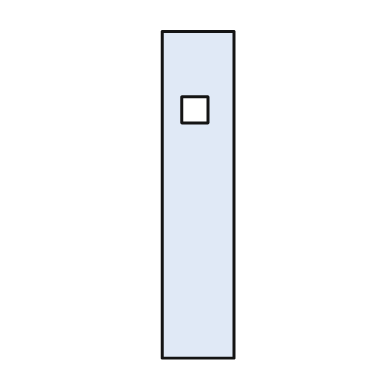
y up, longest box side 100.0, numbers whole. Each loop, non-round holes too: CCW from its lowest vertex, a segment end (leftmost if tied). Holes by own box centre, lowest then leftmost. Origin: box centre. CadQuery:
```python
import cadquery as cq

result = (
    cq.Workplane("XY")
    .moveTo(-11.0, -50.0)
    .lineTo(11.0, -50.0)
    .lineTo(11.0, 50.0)
    .lineTo(-11.0, 50.0)
    .close()
    .moveTo(-5.0, 22.0)
    .lineTo(3.0, 22.0)
    .lineTo(3.0, 30.0)
    .lineTo(-5.0, 30.0)
    .close()
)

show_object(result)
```